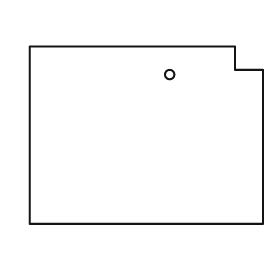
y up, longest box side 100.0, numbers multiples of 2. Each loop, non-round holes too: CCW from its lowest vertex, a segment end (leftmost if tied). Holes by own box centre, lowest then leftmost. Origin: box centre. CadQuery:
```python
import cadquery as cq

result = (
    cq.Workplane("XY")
    .moveTo(-50.0, -38.0)
    .lineTo(50.0, -38.0)
    .lineTo(50.0, 28.0)
    .lineTo(38.0, 28.0)
    .lineTo(38.0, 38.0)
    .lineTo(-50.0, 38.0)
    .close()
    .moveTo(10.0, 26.0)
    .circle(2.0)
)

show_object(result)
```